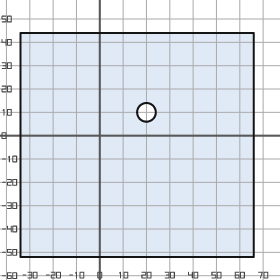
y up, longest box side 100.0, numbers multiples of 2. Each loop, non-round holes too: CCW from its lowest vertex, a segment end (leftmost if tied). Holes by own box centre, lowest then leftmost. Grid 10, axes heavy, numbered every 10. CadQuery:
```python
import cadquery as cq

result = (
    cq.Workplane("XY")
    .moveTo(-34.0, -52.0)
    .lineTo(66.0, -52.0)
    .lineTo(66.0, 44.0)
    .lineTo(-34.0, 44.0)
    .close()
    .moveTo(20.0, 10.0)
    .circle(4.0)
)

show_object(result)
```